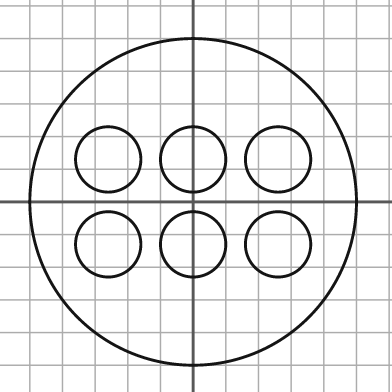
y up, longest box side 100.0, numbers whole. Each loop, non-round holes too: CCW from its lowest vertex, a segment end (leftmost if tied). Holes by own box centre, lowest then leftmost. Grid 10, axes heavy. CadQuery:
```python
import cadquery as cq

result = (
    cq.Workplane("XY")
    .moveTo(0.0, 0.0)
    .circle(50.0)
    .moveTo(-26.0, -13.0)
    .circle(10.0)
    .moveTo(0.0, -13.0)
    .circle(10.0)
    .moveTo(26.0, -13.0)
    .circle(10.0)
    .moveTo(-26.0, 13.0)
    .circle(10.0)
    .moveTo(0.0, 13.0)
    .circle(10.0)
    .moveTo(26.0, 13.0)
    .circle(10.0)
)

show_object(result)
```